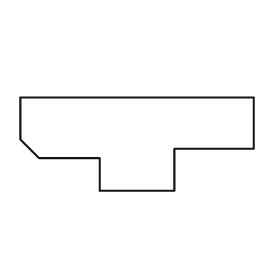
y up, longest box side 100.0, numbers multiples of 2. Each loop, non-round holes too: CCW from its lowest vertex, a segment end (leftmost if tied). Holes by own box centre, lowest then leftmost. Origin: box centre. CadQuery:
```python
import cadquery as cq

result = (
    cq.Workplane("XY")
    .moveTo(-16.0, -20.0)
    .lineTo(16.0, -20.0)
    .lineTo(16.0, -2.0)
    .lineTo(50.0, -2.0)
    .lineTo(50.0, 20.0)
    .lineTo(-50.0, 20.0)
    .lineTo(-50.0, 2.0)
    .lineTo(-42.0, -6.0)
    .lineTo(-16.0, -6.0)
    .close()
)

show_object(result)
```